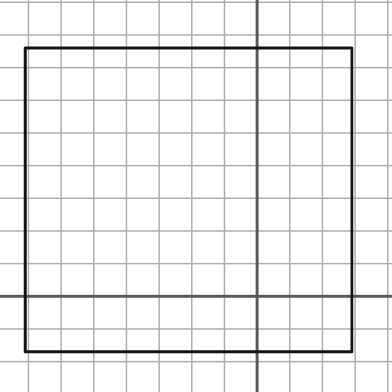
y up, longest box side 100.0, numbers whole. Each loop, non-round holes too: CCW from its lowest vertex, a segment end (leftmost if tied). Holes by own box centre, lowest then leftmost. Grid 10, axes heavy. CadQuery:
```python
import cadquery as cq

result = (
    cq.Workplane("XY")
    .moveTo(-71.0, -17.0)
    .lineTo(29.0, -17.0)
    .lineTo(29.0, 76.0)
    .lineTo(-71.0, 76.0)
    .close()
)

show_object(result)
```